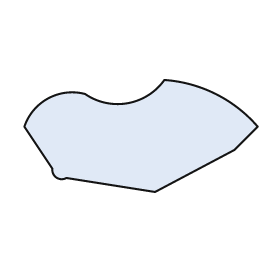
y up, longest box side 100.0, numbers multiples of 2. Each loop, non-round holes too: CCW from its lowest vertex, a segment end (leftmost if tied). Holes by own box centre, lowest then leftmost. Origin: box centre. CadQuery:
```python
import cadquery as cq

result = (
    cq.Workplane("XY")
    .moveTo(6.0, -24.0)
    .lineTo(40.0, -6.0)
    .lineTo(50.0, 4.0)
    .threePointArc((32.0, 18.0), (10.0, 24.0))
    .threePointArc((-6.0, 14.0), (-24.0, 18.0))
    .threePointArc((-40.0, 16.0), (-50.0, 4.0))
    .lineTo(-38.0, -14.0)
    .threePointArc((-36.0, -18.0), (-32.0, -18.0))
    .close()
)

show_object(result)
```